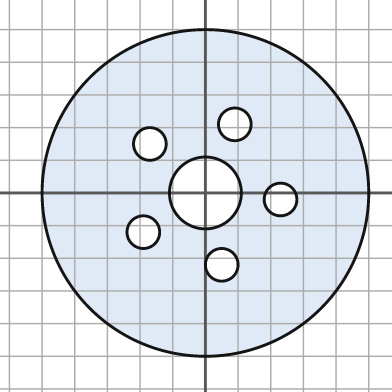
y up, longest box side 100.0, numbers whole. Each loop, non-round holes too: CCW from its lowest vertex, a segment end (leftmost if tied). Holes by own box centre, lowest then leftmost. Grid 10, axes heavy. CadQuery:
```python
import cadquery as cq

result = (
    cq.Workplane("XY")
    .moveTo(0.0, 0.0)
    .circle(50.0)
    .moveTo(5.0, -22.0)
    .circle(5.0)
    .moveTo(-19.0, -12.0)
    .circle(5.0)
    .moveTo(23.0, -2.0)
    .circle(5.0)
    .moveTo(0.0, 0.0)
    .circle(11.0)
    .moveTo(-17.0, 15.0)
    .circle(5.0)
    .moveTo(9.0, 21.0)
    .circle(5.0)
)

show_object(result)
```